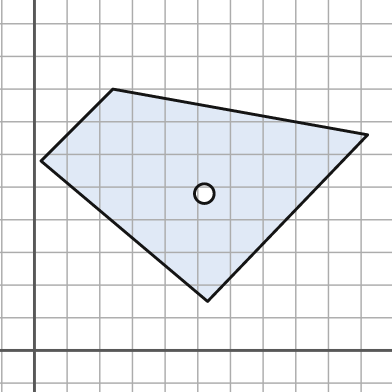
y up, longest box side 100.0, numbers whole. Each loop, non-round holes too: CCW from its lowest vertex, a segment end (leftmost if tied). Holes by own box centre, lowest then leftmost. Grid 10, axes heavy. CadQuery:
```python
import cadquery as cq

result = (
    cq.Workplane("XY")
    .moveTo(53.0, 15.0)
    .lineTo(102.0, 66.0)
    .lineTo(24.0, 80.0)
    .lineTo(2.0, 58.0)
    .close()
    .moveTo(52.0, 48.0)
    .circle(3.0)
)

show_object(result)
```